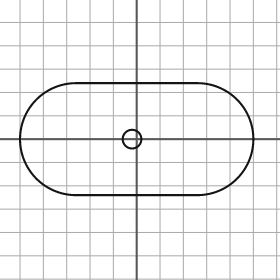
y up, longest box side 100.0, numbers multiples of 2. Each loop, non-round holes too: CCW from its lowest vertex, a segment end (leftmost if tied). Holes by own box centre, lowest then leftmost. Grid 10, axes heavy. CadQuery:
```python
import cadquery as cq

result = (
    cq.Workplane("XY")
    .moveTo(-26.0, -24.0)
    .lineTo(26.0, -24.0)
    .threePointArc((50.0, 0.0), (26.0, 24.0))
    .lineTo(-26.0, 24.0)
    .threePointArc((-50.0, 0.0), (-26.0, -24.0))
    .close()
    .moveTo(-2.0, 0.0)
    .circle(4.0)
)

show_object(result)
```